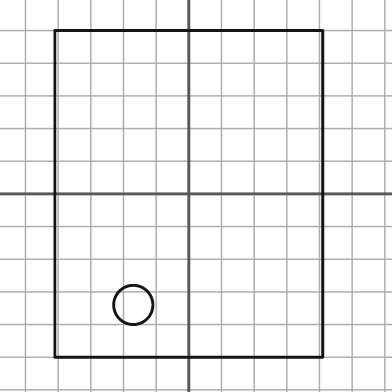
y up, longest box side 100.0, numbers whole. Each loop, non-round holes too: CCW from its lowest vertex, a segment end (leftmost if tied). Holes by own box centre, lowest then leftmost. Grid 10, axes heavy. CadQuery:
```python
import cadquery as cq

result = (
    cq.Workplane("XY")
    .moveTo(-41.0, -50.0)
    .lineTo(41.0, -50.0)
    .lineTo(41.0, 50.0)
    .lineTo(-41.0, 50.0)
    .close()
    .moveTo(-17.0, -34.0)
    .circle(6.0)
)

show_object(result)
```